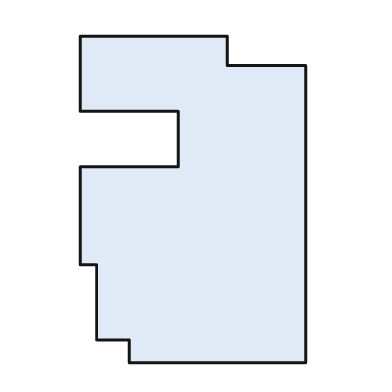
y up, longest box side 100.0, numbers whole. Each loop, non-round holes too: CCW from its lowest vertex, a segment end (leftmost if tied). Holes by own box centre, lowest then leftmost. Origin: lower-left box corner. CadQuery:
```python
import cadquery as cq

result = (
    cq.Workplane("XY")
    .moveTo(15.0, 0.0)
    .lineTo(69.0, 0.0)
    .lineTo(69.0, 91.0)
    .lineTo(45.0, 91.0)
    .lineTo(45.0, 100.0)
    .lineTo(0.0, 100.0)
    .lineTo(0.0, 77.0)
    .lineTo(30.0, 77.0)
    .lineTo(30.0, 60.0)
    .lineTo(0.0, 60.0)
    .lineTo(0.0, 30.0)
    .lineTo(5.0, 30.0)
    .lineTo(5.0, 7.0)
    .lineTo(15.0, 7.0)
    .close()
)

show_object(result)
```